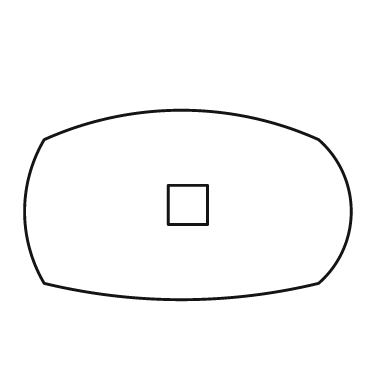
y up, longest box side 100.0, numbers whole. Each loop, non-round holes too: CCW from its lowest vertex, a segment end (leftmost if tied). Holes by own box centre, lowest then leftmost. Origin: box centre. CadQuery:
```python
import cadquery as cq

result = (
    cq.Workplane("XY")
    .moveTo(-44.0, -24.0)
    .threePointArc((-2.0, -29.0), (40.0, -24.0))
    .threePointArc((50.0, -2.0), (40.0, 20.0))
    .threePointArc((-2.0, 29.0), (-44.0, 20.0))
    .threePointArc((-50.0, -2.0), (-44.0, -24.0))
    .close()
    .moveTo(-6.0, -6.0)
    .lineTo(6.0, -6.0)
    .lineTo(6.0, 6.0)
    .lineTo(-6.0, 6.0)
    .close()
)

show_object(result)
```